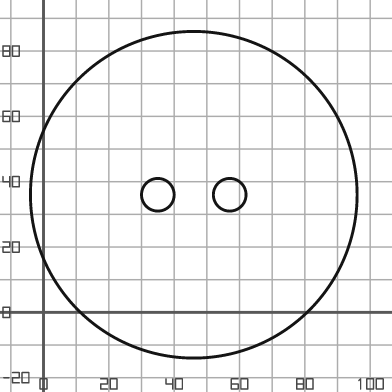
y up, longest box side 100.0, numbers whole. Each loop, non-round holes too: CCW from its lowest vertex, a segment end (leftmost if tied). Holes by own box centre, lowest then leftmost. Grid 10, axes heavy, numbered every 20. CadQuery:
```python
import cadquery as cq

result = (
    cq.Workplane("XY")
    .moveTo(46.0, 36.0)
    .circle(50.0)
    .moveTo(35.0, 36.0)
    .circle(5.0)
    .moveTo(57.0, 36.0)
    .circle(5.0)
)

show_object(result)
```